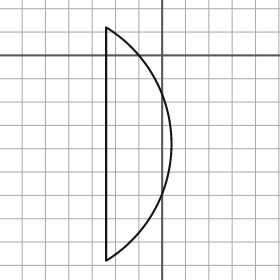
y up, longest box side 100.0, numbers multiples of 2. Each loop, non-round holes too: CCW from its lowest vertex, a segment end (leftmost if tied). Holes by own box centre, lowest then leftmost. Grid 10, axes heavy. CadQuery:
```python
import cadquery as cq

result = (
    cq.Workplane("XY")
    .moveTo(-24.0, -88.0)
    .threePointArc((4.0, -38.0), (-24.0, 12.0))
    .close()
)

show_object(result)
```